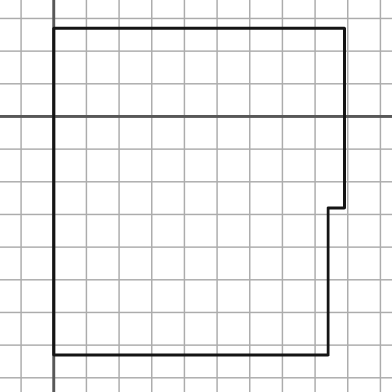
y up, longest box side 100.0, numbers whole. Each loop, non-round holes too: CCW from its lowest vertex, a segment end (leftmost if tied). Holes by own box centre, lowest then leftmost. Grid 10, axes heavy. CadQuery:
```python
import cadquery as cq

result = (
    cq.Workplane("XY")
    .moveTo(0.0, -73.0)
    .lineTo(84.0, -73.0)
    .lineTo(84.0, -28.0)
    .lineTo(89.0, -28.0)
    .lineTo(89.0, 27.0)
    .lineTo(0.0, 27.0)
    .close()
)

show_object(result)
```